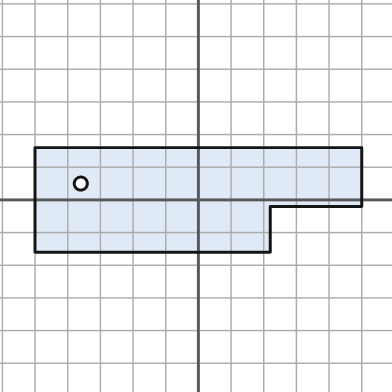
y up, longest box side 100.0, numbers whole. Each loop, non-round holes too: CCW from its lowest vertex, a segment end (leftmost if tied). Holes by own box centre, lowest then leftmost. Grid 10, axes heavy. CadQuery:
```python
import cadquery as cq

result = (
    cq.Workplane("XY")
    .moveTo(-50.0, -16.0)
    .lineTo(22.0, -16.0)
    .lineTo(22.0, -2.0)
    .lineTo(50.0, -2.0)
    .lineTo(50.0, 16.0)
    .lineTo(-50.0, 16.0)
    .close()
    .moveTo(-36.0, 5.0)
    .circle(2.0)
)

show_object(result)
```